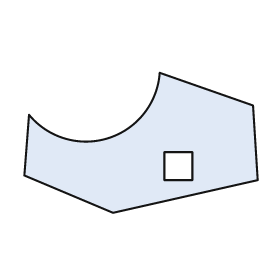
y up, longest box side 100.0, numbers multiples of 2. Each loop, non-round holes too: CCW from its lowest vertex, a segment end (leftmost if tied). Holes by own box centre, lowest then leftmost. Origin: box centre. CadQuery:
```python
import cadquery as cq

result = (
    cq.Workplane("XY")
    .moveTo(-12.0, -30.0)
    .lineTo(50.0, -16.0)
    .lineTo(48.0, 16.0)
    .lineTo(8.0, 30.0)
    .threePointArc((-14.0, 2.0), (-48.0, 12.0))
    .lineTo(-50.0, -14.0)
    .close()
    .moveTo(10.0, -16.0)
    .lineTo(22.0, -16.0)
    .lineTo(22.0, -4.0)
    .lineTo(10.0, -4.0)
    .close()
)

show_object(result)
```